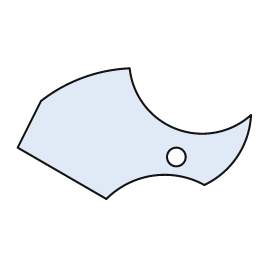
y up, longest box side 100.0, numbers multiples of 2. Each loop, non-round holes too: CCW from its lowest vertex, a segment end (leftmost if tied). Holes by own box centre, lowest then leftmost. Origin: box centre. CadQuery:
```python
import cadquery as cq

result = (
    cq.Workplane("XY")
    .moveTo(-12.0, -28.0)
    .threePointArc((8.0, -18.0), (30.0, -22.0))
    .threePointArc((44.0, -10.0), (50.0, 8.0))
    .threePointArc((18.0, 2.0), (-2.0, 28.0))
    .threePointArc((-22.0, 24.0), (-40.0, 14.0))
    .lineTo(-50.0, -6.0)
    .close()
    .moveTo(18.0, -10.0)
    .circle(4.0)
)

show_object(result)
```